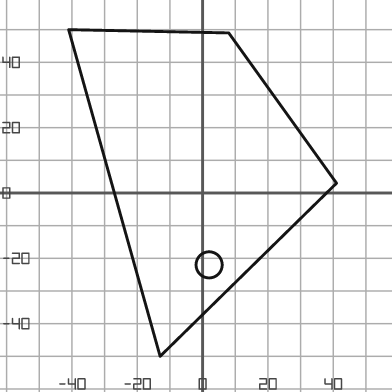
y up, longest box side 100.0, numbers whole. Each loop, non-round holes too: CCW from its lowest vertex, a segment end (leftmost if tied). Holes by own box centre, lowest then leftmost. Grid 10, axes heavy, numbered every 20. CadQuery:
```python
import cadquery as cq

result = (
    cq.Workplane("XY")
    .moveTo(-13.0, -50.0)
    .lineTo(41.0, 3.0)
    .lineTo(8.0, 49.0)
    .lineTo(-41.0, 50.0)
    .close()
    .moveTo(2.0, -22.0)
    .circle(4.0)
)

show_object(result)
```